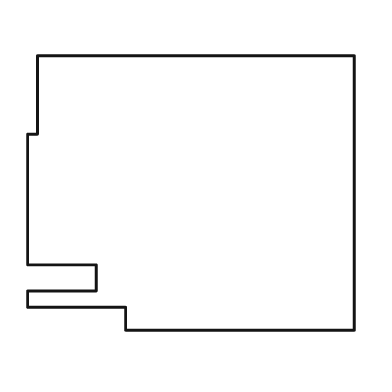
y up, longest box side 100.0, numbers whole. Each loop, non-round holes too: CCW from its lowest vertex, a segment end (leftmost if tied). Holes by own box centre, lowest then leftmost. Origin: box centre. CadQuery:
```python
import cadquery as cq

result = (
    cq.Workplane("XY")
    .moveTo(-20.0, -42.0)
    .lineTo(50.0, -42.0)
    .lineTo(50.0, 42.0)
    .lineTo(-47.0, 42.0)
    .lineTo(-47.0, 18.0)
    .lineTo(-50.0, 18.0)
    .lineTo(-50.0, -22.0)
    .lineTo(-29.0, -22.0)
    .lineTo(-29.0, -30.0)
    .lineTo(-50.0, -30.0)
    .lineTo(-50.0, -35.0)
    .lineTo(-20.0, -35.0)
    .close()
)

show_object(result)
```